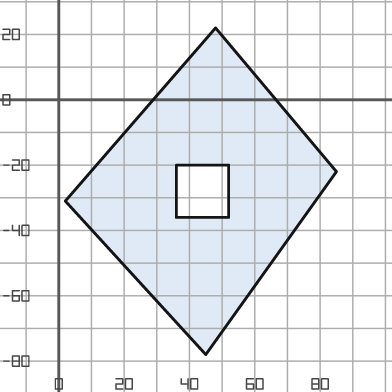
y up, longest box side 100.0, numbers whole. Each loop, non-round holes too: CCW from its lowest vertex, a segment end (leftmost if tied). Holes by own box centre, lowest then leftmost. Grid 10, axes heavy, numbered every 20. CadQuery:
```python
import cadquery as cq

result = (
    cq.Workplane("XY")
    .moveTo(45.0, -78.0)
    .lineTo(85.0, -22.0)
    .lineTo(48.0, 22.0)
    .lineTo(2.0, -31.0)
    .close()
    .moveTo(36.0, -36.0)
    .lineTo(52.0, -36.0)
    .lineTo(52.0, -20.0)
    .lineTo(36.0, -20.0)
    .close()
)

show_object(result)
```